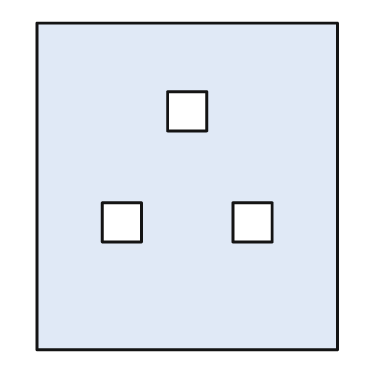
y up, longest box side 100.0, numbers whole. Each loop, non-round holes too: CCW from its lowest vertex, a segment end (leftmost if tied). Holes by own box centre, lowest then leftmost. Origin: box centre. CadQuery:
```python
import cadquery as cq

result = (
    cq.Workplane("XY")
    .moveTo(-46.0, -50.0)
    .lineTo(46.0, -50.0)
    .lineTo(46.0, 50.0)
    .lineTo(-46.0, 50.0)
    .close()
    .moveTo(-26.0, -17.0)
    .lineTo(-14.0, -17.0)
    .lineTo(-14.0, -5.0)
    .lineTo(-26.0, -5.0)
    .close()
    .moveTo(14.0, -17.0)
    .lineTo(26.0, -17.0)
    .lineTo(26.0, -5.0)
    .lineTo(14.0, -5.0)
    .close()
    .moveTo(-6.0, 17.0)
    .lineTo(6.0, 17.0)
    .lineTo(6.0, 29.0)
    .lineTo(-6.0, 29.0)
    .close()
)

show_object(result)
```